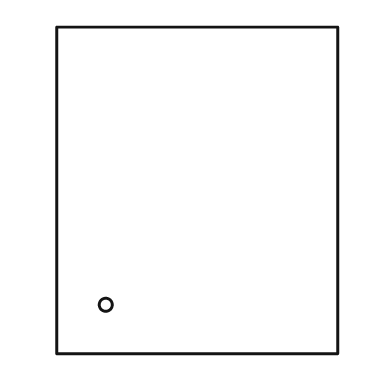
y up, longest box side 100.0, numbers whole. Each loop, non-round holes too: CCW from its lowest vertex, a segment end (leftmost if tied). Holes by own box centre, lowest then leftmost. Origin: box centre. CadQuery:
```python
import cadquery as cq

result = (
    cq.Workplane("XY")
    .moveTo(-43.0, -50.0)
    .lineTo(43.0, -50.0)
    .lineTo(43.0, 50.0)
    .lineTo(-43.0, 50.0)
    .close()
    .moveTo(-28.0, -35.0)
    .circle(2.0)
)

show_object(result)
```